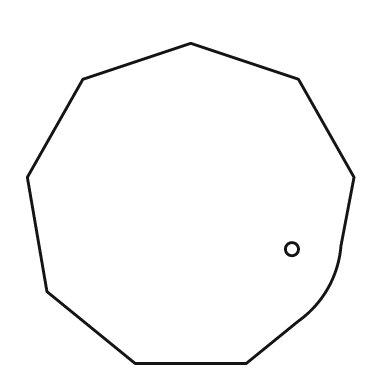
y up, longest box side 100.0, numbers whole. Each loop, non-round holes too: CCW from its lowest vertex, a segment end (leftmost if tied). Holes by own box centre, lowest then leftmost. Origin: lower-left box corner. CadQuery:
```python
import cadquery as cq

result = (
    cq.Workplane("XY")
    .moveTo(33.0, 0.0)
    .lineTo(67.0, 0.0)
    .lineTo(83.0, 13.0)
    .threePointArc((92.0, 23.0), (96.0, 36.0))
    .lineTo(100.0, 57.0)
    .lineTo(83.0, 87.0)
    .lineTo(50.0, 98.0)
    .lineTo(17.0, 87.0)
    .lineTo(0.0, 57.0)
    .lineTo(6.0, 22.0)
    .close()
    .moveTo(81.0, 35.0)
    .circle(2.0)
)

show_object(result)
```